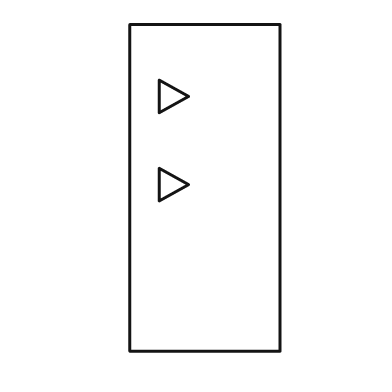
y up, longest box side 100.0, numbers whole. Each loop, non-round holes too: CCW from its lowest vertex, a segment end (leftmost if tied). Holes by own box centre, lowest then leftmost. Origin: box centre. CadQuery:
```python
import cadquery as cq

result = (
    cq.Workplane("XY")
    .moveTo(-23.0, -50.0)
    .lineTo(23.0, -50.0)
    .lineTo(23.0, 50.0)
    .lineTo(-23.0, 50.0)
    .close()
    .moveTo(-14.0, -4.0)
    .lineTo(-5.0, 1.0)
    .lineTo(-14.0, 6.0)
    .close()
    .moveTo(-14.0, 23.0)
    .lineTo(-5.0, 28.0)
    .lineTo(-14.0, 33.0)
    .close()
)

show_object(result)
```